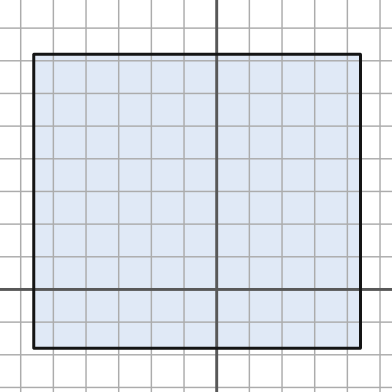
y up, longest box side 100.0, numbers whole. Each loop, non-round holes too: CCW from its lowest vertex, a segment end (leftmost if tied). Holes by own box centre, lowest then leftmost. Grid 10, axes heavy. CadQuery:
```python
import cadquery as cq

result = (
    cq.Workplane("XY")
    .moveTo(-56.0, -18.0)
    .lineTo(44.0, -18.0)
    .lineTo(44.0, 72.0)
    .lineTo(-56.0, 72.0)
    .close()
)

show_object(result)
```